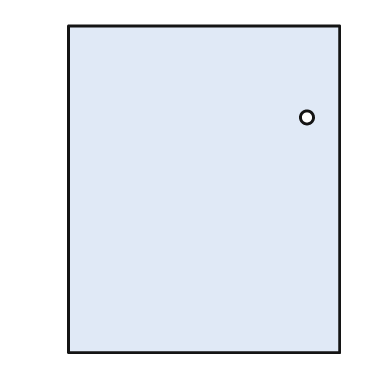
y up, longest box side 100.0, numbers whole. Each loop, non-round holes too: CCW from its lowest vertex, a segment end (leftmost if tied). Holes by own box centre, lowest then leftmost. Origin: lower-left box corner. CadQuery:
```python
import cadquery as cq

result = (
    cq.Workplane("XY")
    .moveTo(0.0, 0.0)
    .lineTo(83.0, 0.0)
    .lineTo(83.0, 100.0)
    .lineTo(0.0, 100.0)
    .close()
    .moveTo(73.0, 72.0)
    .circle(2.0)
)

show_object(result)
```